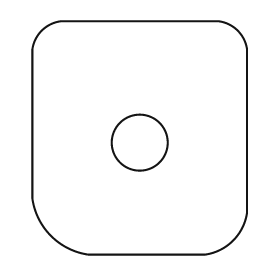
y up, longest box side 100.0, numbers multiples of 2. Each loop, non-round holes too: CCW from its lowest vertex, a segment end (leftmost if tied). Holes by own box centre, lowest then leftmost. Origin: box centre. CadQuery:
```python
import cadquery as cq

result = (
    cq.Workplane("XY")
    .moveTo(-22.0, -50.0)
    .lineTo(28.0, -50.0)
    .threePointArc((40.0, -44.0), (46.0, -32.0))
    .lineTo(46.0, 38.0)
    .threePointArc((42.0, 46.0), (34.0, 50.0))
    .lineTo(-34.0, 50.0)
    .threePointArc((-42.0, 46.0), (-46.0, 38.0))
    .lineTo(-46.0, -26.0)
    .threePointArc((-38.0, -42.0), (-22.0, -50.0))
    .close()
    .moveTo(0.0, -2.0)
    .circle(12.0)
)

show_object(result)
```